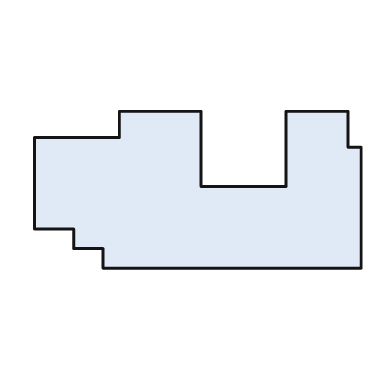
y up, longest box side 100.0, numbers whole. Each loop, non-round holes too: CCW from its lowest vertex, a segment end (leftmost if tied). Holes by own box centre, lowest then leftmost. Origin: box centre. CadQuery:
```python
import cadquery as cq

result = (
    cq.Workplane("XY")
    .moveTo(-29.0, -24.0)
    .lineTo(50.0, -24.0)
    .lineTo(50.0, 13.0)
    .lineTo(46.0, 13.0)
    .lineTo(46.0, 24.0)
    .lineTo(27.0, 24.0)
    .lineTo(27.0, 1.0)
    .lineTo(1.0, 1.0)
    .lineTo(1.0, 24.0)
    .lineTo(-24.0, 24.0)
    .lineTo(-24.0, 16.0)
    .lineTo(-50.0, 16.0)
    .lineTo(-50.0, -12.0)
    .lineTo(-38.0, -12.0)
    .lineTo(-38.0, -18.0)
    .lineTo(-29.0, -18.0)
    .close()
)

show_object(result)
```